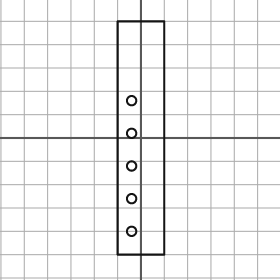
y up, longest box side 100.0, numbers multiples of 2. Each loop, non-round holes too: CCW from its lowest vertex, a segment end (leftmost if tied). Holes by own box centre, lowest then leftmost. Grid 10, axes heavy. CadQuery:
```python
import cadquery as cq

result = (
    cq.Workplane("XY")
    .moveTo(-10.0, -50.0)
    .lineTo(10.0, -50.0)
    .lineTo(10.0, 50.0)
    .lineTo(-10.0, 50.0)
    .close()
    .moveTo(-4.0, -40.0)
    .circle(2.0)
    .moveTo(-4.0, -26.0)
    .circle(2.0)
    .moveTo(-4.0, -12.0)
    .circle(2.0)
    .moveTo(-4.0, 2.0)
    .circle(2.0)
    .moveTo(-4.0, 16.0)
    .circle(2.0)
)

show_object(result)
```